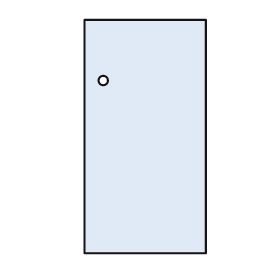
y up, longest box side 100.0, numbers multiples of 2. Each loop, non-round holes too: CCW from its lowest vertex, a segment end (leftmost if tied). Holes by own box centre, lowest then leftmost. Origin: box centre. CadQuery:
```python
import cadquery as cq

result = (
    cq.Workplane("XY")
    .moveTo(-26.0, -50.0)
    .lineTo(26.0, -50.0)
    .lineTo(26.0, 50.0)
    .lineTo(-26.0, 50.0)
    .close()
    .moveTo(-18.0, 24.0)
    .circle(2.0)
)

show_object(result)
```